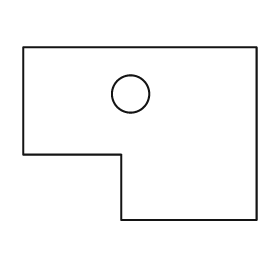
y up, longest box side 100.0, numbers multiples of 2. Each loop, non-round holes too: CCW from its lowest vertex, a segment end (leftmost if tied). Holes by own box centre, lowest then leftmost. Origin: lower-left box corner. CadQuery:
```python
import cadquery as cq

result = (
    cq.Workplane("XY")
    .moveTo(42.0, 0.0)
    .lineTo(100.0, 0.0)
    .lineTo(100.0, 74.0)
    .lineTo(0.0, 74.0)
    .lineTo(0.0, 28.0)
    .lineTo(42.0, 28.0)
    .close()
    .moveTo(46.0, 54.0)
    .circle(8.0)
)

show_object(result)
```